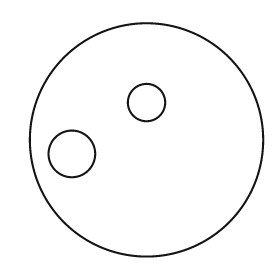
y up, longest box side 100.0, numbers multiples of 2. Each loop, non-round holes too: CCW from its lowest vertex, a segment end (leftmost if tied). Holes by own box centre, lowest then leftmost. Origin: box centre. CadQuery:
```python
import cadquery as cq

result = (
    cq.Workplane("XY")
    .moveTo(0.0, 0.0)
    .circle(50.0)
    .moveTo(-32.0, -6.0)
    .circle(10.0)
    .moveTo(0.0, 16.0)
    .circle(8.0)
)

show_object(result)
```